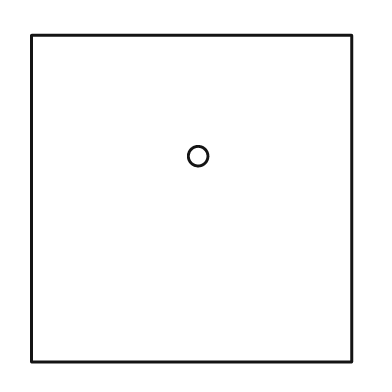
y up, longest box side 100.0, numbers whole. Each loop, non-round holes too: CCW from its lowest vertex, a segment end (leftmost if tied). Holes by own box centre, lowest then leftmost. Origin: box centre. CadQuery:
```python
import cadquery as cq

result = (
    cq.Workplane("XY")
    .moveTo(-49.0, -50.0)
    .lineTo(49.0, -50.0)
    .lineTo(49.0, 50.0)
    .lineTo(-49.0, 50.0)
    .close()
    .moveTo(2.0, 13.0)
    .circle(3.0)
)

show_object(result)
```